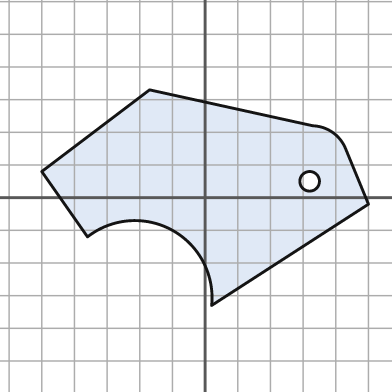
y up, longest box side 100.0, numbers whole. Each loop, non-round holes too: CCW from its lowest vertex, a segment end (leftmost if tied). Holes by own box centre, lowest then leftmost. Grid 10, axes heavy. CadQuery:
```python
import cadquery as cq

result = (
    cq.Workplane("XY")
    .moveTo(2.0, -33.0)
    .lineTo(50.0, -2.0)
    .lineTo(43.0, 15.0)
    .threePointArc((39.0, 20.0), (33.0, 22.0))
    .lineTo(-17.0, 33.0)
    .lineTo(-50.0, 8.0)
    .lineTo(-36.0, -12.0)
    .threePointArc((-10.0, -10.0), (2.0, -33.0))
    .close()
    .moveTo(32.0, 5.0)
    .circle(3.0)
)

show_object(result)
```